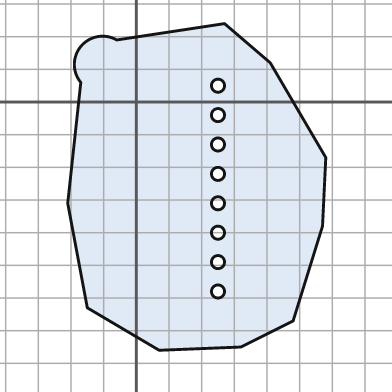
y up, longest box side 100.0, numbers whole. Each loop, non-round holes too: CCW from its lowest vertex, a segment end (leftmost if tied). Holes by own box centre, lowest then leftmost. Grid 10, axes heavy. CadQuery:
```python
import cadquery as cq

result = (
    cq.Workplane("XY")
    .moveTo(7.0, -76.0)
    .lineTo(32.0, -75.0)
    .lineTo(48.0, -67.0)
    .lineTo(57.0, -38.0)
    .lineTo(58.0, -17.0)
    .lineTo(41.0, 12.0)
    .lineTo(27.0, 24.0)
    .lineTo(-6.0, 19.0)
    .threePointArc((-17.0, 17.0), (-17.0, 6.0))
    .lineTo(-21.0, -31.0)
    .lineTo(-15.0, -63.0)
    .close()
    .moveTo(25.0, -58.0)
    .circle(2.0)
    .moveTo(25.0, -49.0)
    .circle(2.0)
    .moveTo(25.0, -40.0)
    .circle(2.0)
    .moveTo(25.0, -31.0)
    .circle(2.0)
    .moveTo(25.0, -22.0)
    .circle(2.0)
    .moveTo(25.0, -13.0)
    .circle(2.0)
    .moveTo(25.0, -4.0)
    .circle(2.0)
    .moveTo(25.0, 5.0)
    .circle(2.0)
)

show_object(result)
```